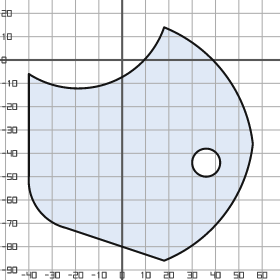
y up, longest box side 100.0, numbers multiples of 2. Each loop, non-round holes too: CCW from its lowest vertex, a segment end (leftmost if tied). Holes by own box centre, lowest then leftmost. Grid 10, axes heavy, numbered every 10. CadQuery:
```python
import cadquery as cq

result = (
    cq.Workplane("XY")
    .moveTo(18.0, -86.0)
    .threePointArc((44.0, -66.0), (56.0, -36.0))
    .threePointArc((44.0, -6.0), (18.0, 14.0))
    .threePointArc((-6.0, -10.0), (-40.0, -6.0))
    .lineTo(-40.0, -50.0)
    .threePointArc((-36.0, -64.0), (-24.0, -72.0))
    .close()
    .moveTo(36.0, -44.0)
    .circle(6.0)
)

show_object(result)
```